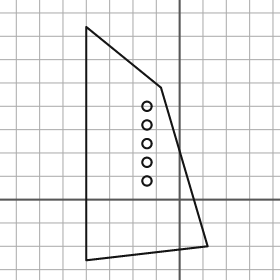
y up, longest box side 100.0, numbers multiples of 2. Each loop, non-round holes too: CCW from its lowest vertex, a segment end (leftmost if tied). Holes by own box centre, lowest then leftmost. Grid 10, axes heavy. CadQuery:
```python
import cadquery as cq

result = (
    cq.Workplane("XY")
    .moveTo(-40.0, -26.0)
    .lineTo(12.0, -20.0)
    .lineTo(-8.0, 48.0)
    .lineTo(-40.0, 74.0)
    .close()
    .moveTo(-14.0, 8.0)
    .circle(2.0)
    .moveTo(-14.0, 16.0)
    .circle(2.0)
    .moveTo(-14.0, 24.0)
    .circle(2.0)
    .moveTo(-14.0, 32.0)
    .circle(2.0)
    .moveTo(-14.0, 40.0)
    .circle(2.0)
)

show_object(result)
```